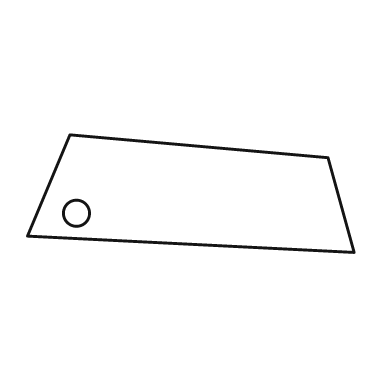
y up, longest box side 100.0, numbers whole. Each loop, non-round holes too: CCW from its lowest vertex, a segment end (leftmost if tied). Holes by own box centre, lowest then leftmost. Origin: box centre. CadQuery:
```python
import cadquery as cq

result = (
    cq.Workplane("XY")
    .moveTo(50.0, -18.0)
    .lineTo(42.0, 11.0)
    .lineTo(-37.0, 18.0)
    .lineTo(-50.0, -13.0)
    .close()
    .moveTo(-35.0, -6.0)
    .circle(4.0)
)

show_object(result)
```